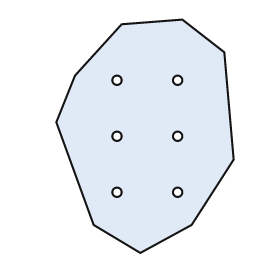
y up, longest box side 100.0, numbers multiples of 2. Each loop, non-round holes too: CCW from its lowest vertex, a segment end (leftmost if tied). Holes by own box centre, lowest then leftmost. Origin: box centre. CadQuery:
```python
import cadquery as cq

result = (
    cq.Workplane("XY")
    .moveTo(-2.0, -50.0)
    .lineTo(20.0, -38.0)
    .lineTo(38.0, -10.0)
    .lineTo(34.0, 36.0)
    .lineTo(16.0, 50.0)
    .lineTo(-10.0, 48.0)
    .lineTo(-30.0, 26.0)
    .lineTo(-38.0, 6.0)
    .lineTo(-22.0, -38.0)
    .close()
    .moveTo(-12.0, -24.0)
    .circle(2.0)
    .moveTo(14.0, -24.0)
    .circle(2.0)
    .moveTo(-12.0, 0.0)
    .circle(2.0)
    .moveTo(14.0, 0.0)
    .circle(2.0)
    .moveTo(-12.0, 24.0)
    .circle(2.0)
    .moveTo(14.0, 24.0)
    .circle(2.0)
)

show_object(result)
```